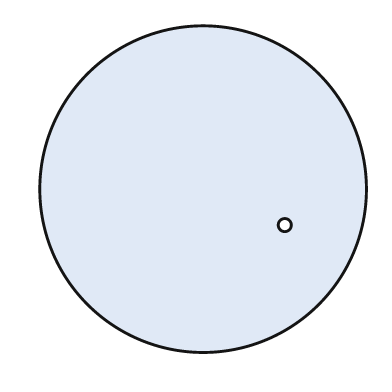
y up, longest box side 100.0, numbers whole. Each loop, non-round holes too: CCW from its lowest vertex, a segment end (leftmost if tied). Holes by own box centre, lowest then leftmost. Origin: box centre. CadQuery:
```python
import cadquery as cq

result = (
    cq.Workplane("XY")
    .moveTo(0.0, 0.0)
    .circle(50.0)
    .moveTo(25.0, -11.0)
    .circle(2.0)
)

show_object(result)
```